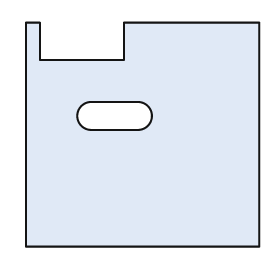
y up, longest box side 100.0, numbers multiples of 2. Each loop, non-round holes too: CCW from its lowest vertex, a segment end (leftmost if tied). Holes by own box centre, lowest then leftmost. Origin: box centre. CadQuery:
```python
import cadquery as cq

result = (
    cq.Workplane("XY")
    .moveTo(-50.0, -48.0)
    .lineTo(50.0, -48.0)
    .lineTo(50.0, 48.0)
    .lineTo(-8.0, 48.0)
    .lineTo(-8.0, 32.0)
    .lineTo(-44.0, 32.0)
    .lineTo(-44.0, 48.0)
    .lineTo(-50.0, 48.0)
    .close()
    .moveTo(-22.0, 2.0)
    .lineTo(-2.0, 2.0)
    .threePointArc((4.0, 8.0), (-2.0, 14.0))
    .lineTo(-22.0, 14.0)
    .threePointArc((-28.0, 8.0), (-22.0, 2.0))
    .close()
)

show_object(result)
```